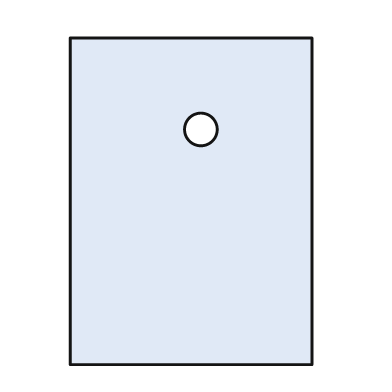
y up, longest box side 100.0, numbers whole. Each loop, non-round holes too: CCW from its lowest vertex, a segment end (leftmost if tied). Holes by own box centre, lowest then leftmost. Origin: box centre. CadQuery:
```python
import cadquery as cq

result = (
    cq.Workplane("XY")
    .moveTo(-37.0, -50.0)
    .lineTo(37.0, -50.0)
    .lineTo(37.0, 50.0)
    .lineTo(-37.0, 50.0)
    .close()
    .moveTo(3.0, 22.0)
    .circle(5.0)
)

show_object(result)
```